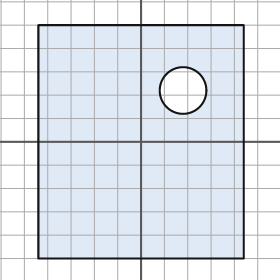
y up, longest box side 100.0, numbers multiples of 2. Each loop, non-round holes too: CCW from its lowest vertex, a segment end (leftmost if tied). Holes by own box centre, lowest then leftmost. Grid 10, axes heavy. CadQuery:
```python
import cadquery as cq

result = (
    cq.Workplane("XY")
    .moveTo(-44.0, -50.0)
    .lineTo(44.0, -50.0)
    .lineTo(44.0, 50.0)
    .lineTo(-44.0, 50.0)
    .close()
    .moveTo(18.0, 22.0)
    .circle(10.0)
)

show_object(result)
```